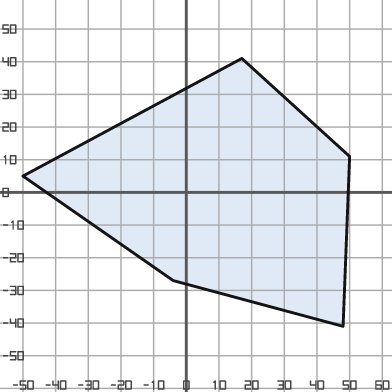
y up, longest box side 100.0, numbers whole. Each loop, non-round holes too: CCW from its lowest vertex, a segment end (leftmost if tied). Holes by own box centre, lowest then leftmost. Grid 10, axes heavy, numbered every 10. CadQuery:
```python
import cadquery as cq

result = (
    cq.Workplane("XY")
    .moveTo(48.0, -41.0)
    .lineTo(50.0, 11.0)
    .lineTo(17.0, 41.0)
    .lineTo(-50.0, 5.0)
    .lineTo(-4.0, -27.0)
    .close()
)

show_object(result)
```